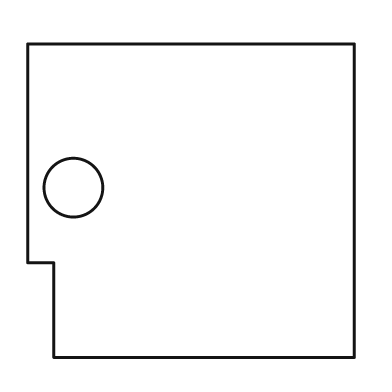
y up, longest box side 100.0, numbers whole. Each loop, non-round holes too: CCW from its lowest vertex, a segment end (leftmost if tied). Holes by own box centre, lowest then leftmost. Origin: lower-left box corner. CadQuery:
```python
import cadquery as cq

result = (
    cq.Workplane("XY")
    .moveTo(8.0, 0.0)
    .lineTo(100.0, 0.0)
    .lineTo(100.0, 96.0)
    .lineTo(0.0, 96.0)
    .lineTo(0.0, 29.0)
    .lineTo(8.0, 29.0)
    .close()
    .moveTo(14.0, 52.0)
    .circle(9.0)
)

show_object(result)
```